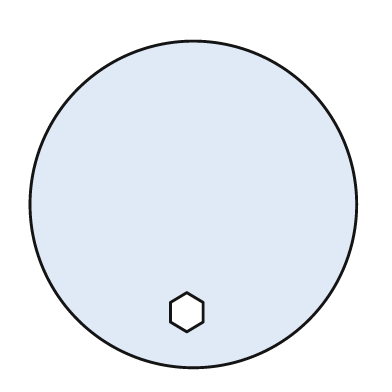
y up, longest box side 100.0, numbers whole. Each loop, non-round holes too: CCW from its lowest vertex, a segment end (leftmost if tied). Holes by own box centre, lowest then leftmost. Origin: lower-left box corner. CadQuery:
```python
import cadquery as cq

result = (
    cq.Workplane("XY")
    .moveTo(50.0, 50.0)
    .circle(50.0)
    .moveTo(48.0, 11.0)
    .lineTo(53.0, 14.0)
    .lineTo(53.0, 20.0)
    .lineTo(48.0, 23.0)
    .lineTo(43.0, 20.0)
    .lineTo(43.0, 14.0)
    .close()
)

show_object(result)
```